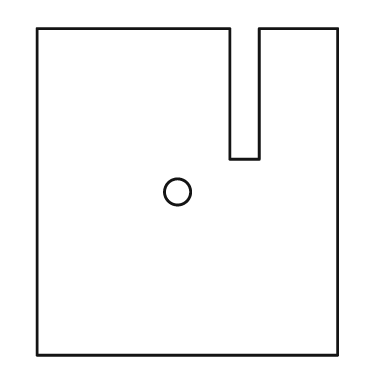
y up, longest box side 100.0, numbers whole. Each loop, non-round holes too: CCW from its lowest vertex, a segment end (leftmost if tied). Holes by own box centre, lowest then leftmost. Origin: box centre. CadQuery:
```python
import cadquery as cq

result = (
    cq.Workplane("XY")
    .moveTo(-46.0, -50.0)
    .lineTo(46.0, -50.0)
    .lineTo(46.0, 50.0)
    .lineTo(22.0, 50.0)
    .lineTo(22.0, 10.0)
    .lineTo(13.0, 10.0)
    .lineTo(13.0, 50.0)
    .lineTo(-46.0, 50.0)
    .close()
    .moveTo(-3.0, 0.0)
    .circle(4.0)
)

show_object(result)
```